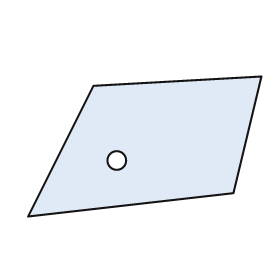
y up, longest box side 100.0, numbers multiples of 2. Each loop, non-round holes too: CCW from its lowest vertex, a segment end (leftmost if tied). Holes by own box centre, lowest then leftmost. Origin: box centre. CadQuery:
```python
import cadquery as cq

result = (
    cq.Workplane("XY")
    .moveTo(-50.0, -30.0)
    .lineTo(38.0, -20.0)
    .lineTo(50.0, 30.0)
    .lineTo(-22.0, 26.0)
    .close()
    .moveTo(-12.0, -6.0)
    .circle(4.0)
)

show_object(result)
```